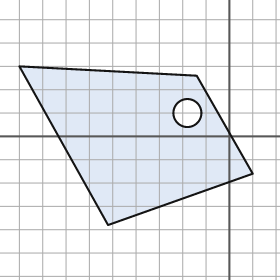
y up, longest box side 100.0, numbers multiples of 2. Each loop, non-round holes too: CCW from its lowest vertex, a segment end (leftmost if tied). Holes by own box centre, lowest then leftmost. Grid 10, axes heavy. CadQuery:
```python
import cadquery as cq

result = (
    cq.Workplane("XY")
    .moveTo(-52.0, -38.0)
    .lineTo(10.0, -16.0)
    .lineTo(-14.0, 26.0)
    .lineTo(-90.0, 30.0)
    .close()
    .moveTo(-18.0, 10.0)
    .circle(6.0)
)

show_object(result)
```